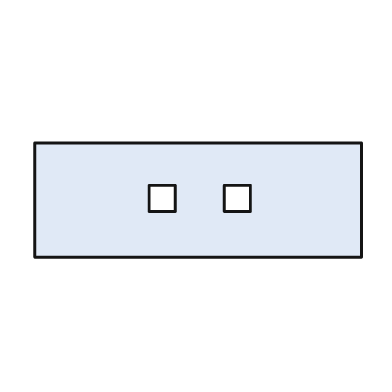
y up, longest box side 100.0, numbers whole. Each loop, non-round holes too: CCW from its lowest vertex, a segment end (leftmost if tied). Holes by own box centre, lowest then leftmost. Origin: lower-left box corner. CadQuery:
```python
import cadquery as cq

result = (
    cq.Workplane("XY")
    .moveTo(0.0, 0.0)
    .lineTo(100.0, 0.0)
    .lineTo(100.0, 35.0)
    .lineTo(0.0, 35.0)
    .close()
    .moveTo(35.0, 14.0)
    .lineTo(43.0, 14.0)
    .lineTo(43.0, 22.0)
    .lineTo(35.0, 22.0)
    .close()
    .moveTo(58.0, 14.0)
    .lineTo(66.0, 14.0)
    .lineTo(66.0, 22.0)
    .lineTo(58.0, 22.0)
    .close()
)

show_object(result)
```